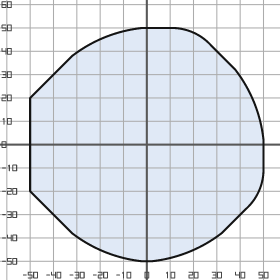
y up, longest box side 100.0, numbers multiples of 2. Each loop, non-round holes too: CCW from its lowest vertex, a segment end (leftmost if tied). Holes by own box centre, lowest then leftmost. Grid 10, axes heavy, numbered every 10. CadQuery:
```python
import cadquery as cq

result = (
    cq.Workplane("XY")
    .moveTo(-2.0, -50.0)
    .lineTo(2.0, -50.0)
    .threePointArc((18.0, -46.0), (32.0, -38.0))
    .lineTo(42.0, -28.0)
    .threePointArc((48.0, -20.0), (50.0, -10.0))
    .lineTo(50.0, 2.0)
    .threePointArc((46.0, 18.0), (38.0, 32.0))
    .lineTo(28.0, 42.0)
    .threePointArc((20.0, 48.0), (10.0, 50.0))
    .lineTo(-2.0, 50.0)
    .threePointArc((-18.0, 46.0), (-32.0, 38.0))
    .lineTo(-50.0, 20.0)
    .lineTo(-50.0, -20.0)
    .lineTo(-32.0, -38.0)
    .threePointArc((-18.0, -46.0), (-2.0, -50.0))
    .close()
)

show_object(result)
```